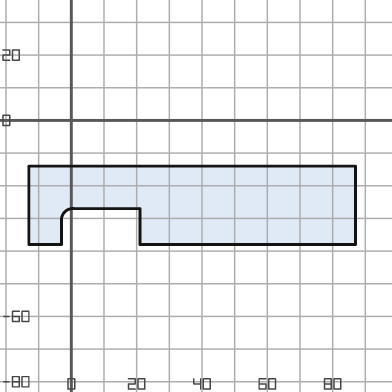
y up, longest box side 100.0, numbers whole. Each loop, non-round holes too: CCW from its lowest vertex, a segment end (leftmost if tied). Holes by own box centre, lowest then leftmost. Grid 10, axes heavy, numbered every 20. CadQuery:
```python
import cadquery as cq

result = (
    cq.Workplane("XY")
    .moveTo(-13.0, -38.0)
    .lineTo(-3.0, -38.0)
    .lineTo(-3.0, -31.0)
    .threePointArc((-2.0, -28.0), (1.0, -27.0))
    .lineTo(21.0, -27.0)
    .lineTo(21.0, -38.0)
    .lineTo(87.0, -38.0)
    .lineTo(87.0, -14.0)
    .lineTo(-13.0, -14.0)
    .close()
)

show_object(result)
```